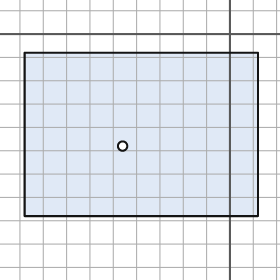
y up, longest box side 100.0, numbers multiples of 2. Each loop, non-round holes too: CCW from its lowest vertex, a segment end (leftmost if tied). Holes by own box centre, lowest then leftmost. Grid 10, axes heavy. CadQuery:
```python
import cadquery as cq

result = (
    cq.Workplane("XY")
    .moveTo(-88.0, -78.0)
    .lineTo(12.0, -78.0)
    .lineTo(12.0, -8.0)
    .lineTo(-88.0, -8.0)
    .close()
    .moveTo(-46.0, -48.0)
    .circle(2.0)
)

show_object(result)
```